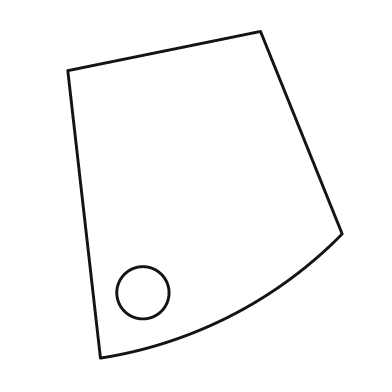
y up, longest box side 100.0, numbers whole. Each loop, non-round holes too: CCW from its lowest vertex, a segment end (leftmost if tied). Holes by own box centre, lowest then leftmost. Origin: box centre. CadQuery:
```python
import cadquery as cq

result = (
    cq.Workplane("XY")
    .moveTo(-32.0, -50.0)
    .threePointArc((8.0, -37.0), (42.0, -12.0))
    .lineTo(17.0, 50.0)
    .lineTo(-42.0, 38.0)
    .close()
    .moveTo(-19.0, -30.0)
    .circle(8.0)
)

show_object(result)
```